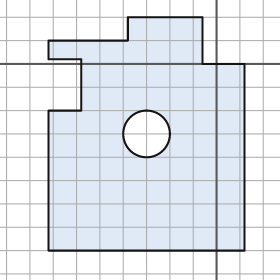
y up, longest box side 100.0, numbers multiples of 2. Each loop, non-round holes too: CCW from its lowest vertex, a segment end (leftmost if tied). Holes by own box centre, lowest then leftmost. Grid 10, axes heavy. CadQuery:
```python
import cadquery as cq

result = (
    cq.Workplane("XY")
    .moveTo(-72.0, -80.0)
    .lineTo(12.0, -80.0)
    .lineTo(12.0, 0.0)
    .lineTo(-6.0, 0.0)
    .lineTo(-6.0, 20.0)
    .lineTo(-38.0, 20.0)
    .lineTo(-38.0, 10.0)
    .lineTo(-72.0, 10.0)
    .lineTo(-72.0, 2.0)
    .lineTo(-58.0, 2.0)
    .lineTo(-58.0, -20.0)
    .lineTo(-72.0, -20.0)
    .close()
    .moveTo(-30.0, -30.0)
    .circle(10.0)
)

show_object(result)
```